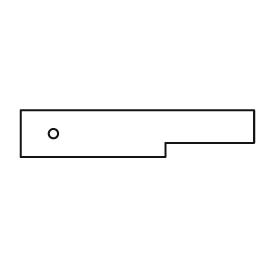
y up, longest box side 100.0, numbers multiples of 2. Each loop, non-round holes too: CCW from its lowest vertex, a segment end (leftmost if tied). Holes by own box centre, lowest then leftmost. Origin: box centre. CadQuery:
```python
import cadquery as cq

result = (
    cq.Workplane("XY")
    .moveTo(-50.0, -10.0)
    .lineTo(12.0, -10.0)
    .lineTo(12.0, -4.0)
    .lineTo(50.0, -4.0)
    .lineTo(50.0, 10.0)
    .lineTo(-50.0, 10.0)
    .close()
    .moveTo(-36.0, 0.0)
    .circle(2.0)
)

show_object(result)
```